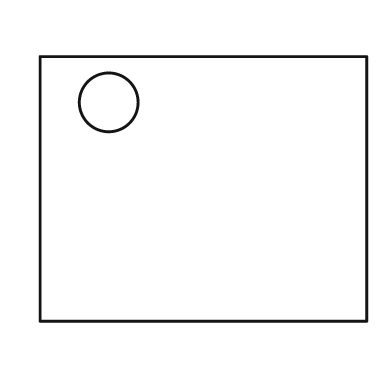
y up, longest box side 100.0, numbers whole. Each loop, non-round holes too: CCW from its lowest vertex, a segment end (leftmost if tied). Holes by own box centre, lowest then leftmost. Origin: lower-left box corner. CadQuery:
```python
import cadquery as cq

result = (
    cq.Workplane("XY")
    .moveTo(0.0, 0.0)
    .lineTo(100.0, 0.0)
    .lineTo(100.0, 81.0)
    .lineTo(0.0, 81.0)
    .close()
    .moveTo(21.0, 67.0)
    .circle(9.0)
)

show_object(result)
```